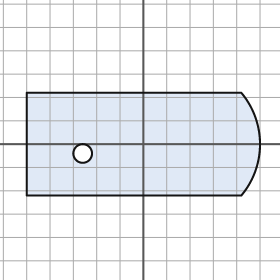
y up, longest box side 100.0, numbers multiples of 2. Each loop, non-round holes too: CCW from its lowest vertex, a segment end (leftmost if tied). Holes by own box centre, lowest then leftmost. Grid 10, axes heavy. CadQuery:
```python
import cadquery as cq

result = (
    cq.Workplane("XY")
    .moveTo(-50.0, -22.0)
    .lineTo(42.0, -22.0)
    .threePointArc((50.0, 0.0), (42.0, 22.0))
    .lineTo(-50.0, 22.0)
    .close()
    .moveTo(-26.0, -4.0)
    .circle(4.0)
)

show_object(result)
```